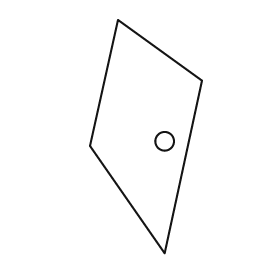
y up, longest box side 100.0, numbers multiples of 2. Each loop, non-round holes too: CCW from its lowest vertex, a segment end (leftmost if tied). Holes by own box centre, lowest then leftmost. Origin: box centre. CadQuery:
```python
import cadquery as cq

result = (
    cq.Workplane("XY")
    .moveTo(8.0, -50.0)
    .lineTo(24.0, 24.0)
    .lineTo(-12.0, 50.0)
    .lineTo(-24.0, -4.0)
    .close()
    .moveTo(8.0, -2.0)
    .circle(4.0)
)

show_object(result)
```